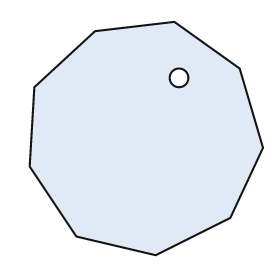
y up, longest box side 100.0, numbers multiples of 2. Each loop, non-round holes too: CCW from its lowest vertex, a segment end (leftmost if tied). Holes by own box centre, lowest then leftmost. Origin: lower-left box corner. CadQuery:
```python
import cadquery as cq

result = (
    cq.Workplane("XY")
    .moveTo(54.0, 0.0)
    .lineTo(86.0, 16.0)
    .lineTo(100.0, 46.0)
    .lineTo(90.0, 80.0)
    .lineTo(62.0, 100.0)
    .lineTo(28.0, 96.0)
    .lineTo(2.0, 72.0)
    .lineTo(0.0, 38.0)
    .lineTo(20.0, 8.0)
    .close()
    .moveTo(64.0, 76.0)
    .circle(4.0)
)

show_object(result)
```